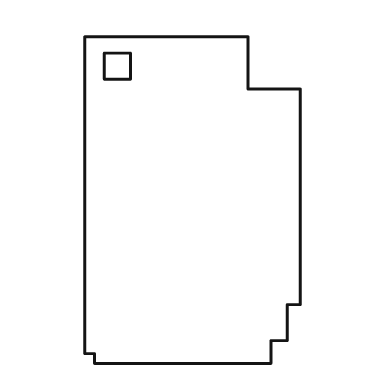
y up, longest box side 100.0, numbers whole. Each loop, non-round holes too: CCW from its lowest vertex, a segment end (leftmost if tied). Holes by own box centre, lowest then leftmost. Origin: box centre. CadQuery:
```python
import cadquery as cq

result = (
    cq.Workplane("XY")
    .moveTo(-30.0, -50.0)
    .lineTo(24.0, -50.0)
    .lineTo(24.0, -43.0)
    .lineTo(29.0, -43.0)
    .lineTo(29.0, -32.0)
    .lineTo(33.0, -32.0)
    .lineTo(33.0, 34.0)
    .lineTo(17.0, 34.0)
    .lineTo(17.0, 50.0)
    .lineTo(-33.0, 50.0)
    .lineTo(-33.0, -47.0)
    .lineTo(-30.0, -47.0)
    .close()
    .moveTo(-27.0, 37.0)
    .lineTo(-19.0, 37.0)
    .lineTo(-19.0, 45.0)
    .lineTo(-27.0, 45.0)
    .close()
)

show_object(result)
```